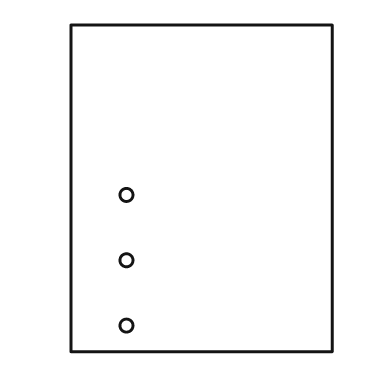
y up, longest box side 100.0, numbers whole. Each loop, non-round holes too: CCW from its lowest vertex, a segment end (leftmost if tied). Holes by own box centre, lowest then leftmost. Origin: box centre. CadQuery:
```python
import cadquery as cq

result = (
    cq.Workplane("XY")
    .moveTo(-40.0, -50.0)
    .lineTo(40.0, -50.0)
    .lineTo(40.0, 50.0)
    .lineTo(-40.0, 50.0)
    .close()
    .moveTo(-23.0, -42.0)
    .circle(2.0)
    .moveTo(-23.0, -22.0)
    .circle(2.0)
    .moveTo(-23.0, -2.0)
    .circle(2.0)
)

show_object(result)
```